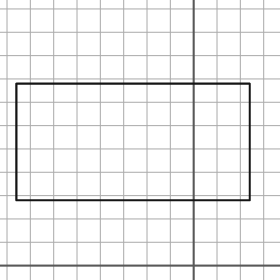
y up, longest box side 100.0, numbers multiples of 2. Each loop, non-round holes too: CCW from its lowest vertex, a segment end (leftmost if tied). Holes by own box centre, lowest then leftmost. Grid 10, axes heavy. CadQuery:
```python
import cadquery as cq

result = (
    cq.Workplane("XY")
    .moveTo(-76.0, 28.0)
    .lineTo(24.0, 28.0)
    .lineTo(24.0, 78.0)
    .lineTo(-76.0, 78.0)
    .close()
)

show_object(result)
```